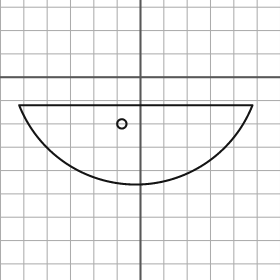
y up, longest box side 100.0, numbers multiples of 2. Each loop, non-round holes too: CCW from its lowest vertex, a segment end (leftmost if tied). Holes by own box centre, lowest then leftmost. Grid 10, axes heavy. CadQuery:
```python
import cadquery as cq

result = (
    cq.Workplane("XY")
    .moveTo(-52.0, -12.0)
    .threePointArc((-2.0, -46.0), (48.0, -12.0))
    .close()
    .moveTo(-8.0, -20.0)
    .circle(2.0)
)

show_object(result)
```